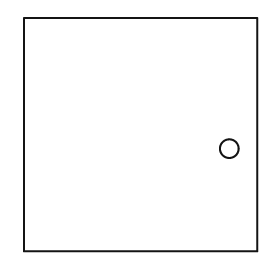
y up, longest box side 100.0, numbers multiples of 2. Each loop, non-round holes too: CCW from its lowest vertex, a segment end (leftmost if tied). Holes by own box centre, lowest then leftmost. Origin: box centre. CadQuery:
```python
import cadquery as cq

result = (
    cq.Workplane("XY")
    .moveTo(-50.0, -50.0)
    .lineTo(50.0, -50.0)
    .lineTo(50.0, 50.0)
    .lineTo(-50.0, 50.0)
    .close()
    .moveTo(38.0, -6.0)
    .circle(4.0)
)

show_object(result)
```